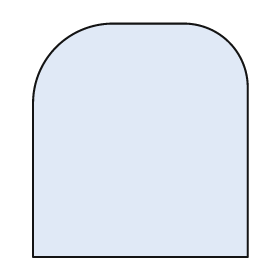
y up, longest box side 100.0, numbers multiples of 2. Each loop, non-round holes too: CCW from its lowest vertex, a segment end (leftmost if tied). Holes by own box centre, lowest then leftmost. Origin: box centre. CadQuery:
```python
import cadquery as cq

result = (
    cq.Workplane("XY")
    .moveTo(-46.0, -50.0)
    .lineTo(46.0, -50.0)
    .lineTo(46.0, 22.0)
    .threePointArc((38.0, 42.0), (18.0, 50.0))
    .lineTo(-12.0, 50.0)
    .threePointArc((-36.0, 40.0), (-46.0, 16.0))
    .close()
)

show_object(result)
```